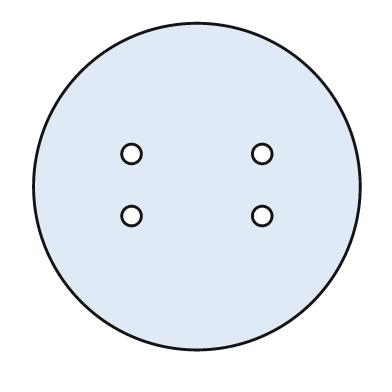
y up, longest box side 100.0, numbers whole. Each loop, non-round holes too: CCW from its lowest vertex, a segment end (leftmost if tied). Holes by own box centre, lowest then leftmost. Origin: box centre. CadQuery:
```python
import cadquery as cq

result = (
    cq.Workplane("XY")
    .moveTo(0.0, 0.0)
    .circle(50.0)
    .moveTo(-20.0, -9.0)
    .circle(3.0)
    .moveTo(20.0, -9.0)
    .circle(3.0)
    .moveTo(-20.0, 10.0)
    .circle(3.0)
    .moveTo(20.0, 10.0)
    .circle(3.0)
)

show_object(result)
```